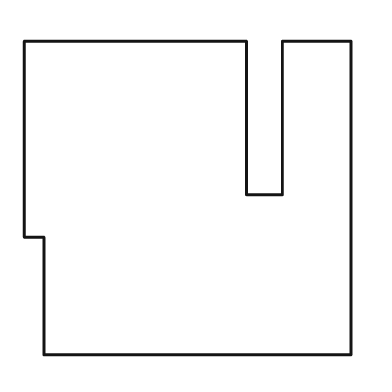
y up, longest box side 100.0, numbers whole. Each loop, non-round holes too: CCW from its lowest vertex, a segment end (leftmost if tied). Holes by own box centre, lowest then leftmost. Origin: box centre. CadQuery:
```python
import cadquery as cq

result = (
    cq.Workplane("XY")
    .moveTo(-44.0, -48.0)
    .lineTo(50.0, -48.0)
    .lineTo(50.0, 48.0)
    .lineTo(29.0, 48.0)
    .lineTo(29.0, 1.0)
    .lineTo(18.0, 1.0)
    .lineTo(18.0, 48.0)
    .lineTo(-50.0, 48.0)
    .lineTo(-50.0, -12.0)
    .lineTo(-44.0, -12.0)
    .close()
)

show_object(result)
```